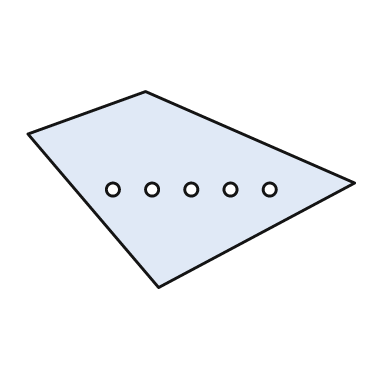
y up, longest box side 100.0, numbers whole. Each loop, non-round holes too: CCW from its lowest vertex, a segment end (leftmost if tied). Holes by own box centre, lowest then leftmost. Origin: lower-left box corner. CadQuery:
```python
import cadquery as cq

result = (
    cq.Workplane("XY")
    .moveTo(40.0, 0.0)
    .lineTo(100.0, 32.0)
    .lineTo(36.0, 60.0)
    .lineTo(0.0, 47.0)
    .close()
    .moveTo(26.0, 30.0)
    .circle(2.0)
    .moveTo(38.0, 30.0)
    .circle(2.0)
    .moveTo(50.0, 30.0)
    .circle(2.0)
    .moveTo(62.0, 30.0)
    .circle(2.0)
    .moveTo(74.0, 30.0)
    .circle(2.0)
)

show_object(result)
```